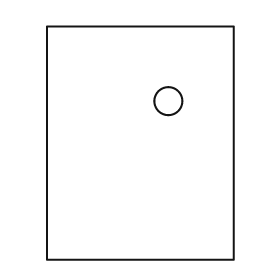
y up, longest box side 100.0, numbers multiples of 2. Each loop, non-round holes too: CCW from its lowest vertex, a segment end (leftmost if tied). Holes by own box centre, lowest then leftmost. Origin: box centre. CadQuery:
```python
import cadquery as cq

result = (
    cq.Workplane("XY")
    .moveTo(-40.0, -50.0)
    .lineTo(40.0, -50.0)
    .lineTo(40.0, 50.0)
    .lineTo(-40.0, 50.0)
    .close()
    .moveTo(12.0, 18.0)
    .circle(6.0)
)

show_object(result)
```